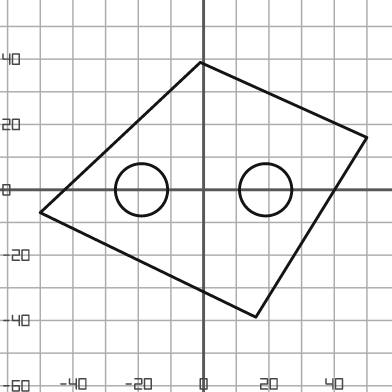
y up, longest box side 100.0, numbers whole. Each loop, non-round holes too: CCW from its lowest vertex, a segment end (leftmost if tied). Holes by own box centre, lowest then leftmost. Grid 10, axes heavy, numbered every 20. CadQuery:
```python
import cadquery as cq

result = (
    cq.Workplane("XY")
    .moveTo(16.0, -39.0)
    .lineTo(50.0, 16.0)
    .lineTo(-1.0, 39.0)
    .lineTo(-50.0, -7.0)
    .close()
    .moveTo(-19.0, 0.0)
    .circle(8.0)
    .moveTo(19.0, 0.0)
    .circle(8.0)
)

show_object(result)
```